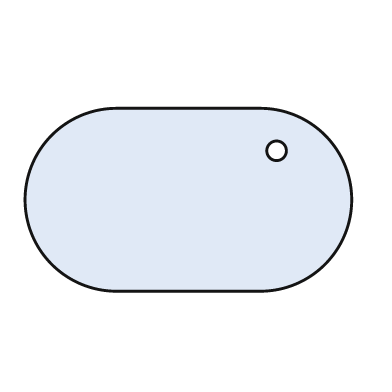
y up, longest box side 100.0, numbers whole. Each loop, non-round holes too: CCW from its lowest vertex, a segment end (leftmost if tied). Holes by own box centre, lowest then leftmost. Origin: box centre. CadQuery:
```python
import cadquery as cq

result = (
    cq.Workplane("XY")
    .moveTo(-22.0, -28.0)
    .lineTo(22.0, -28.0)
    .threePointArc((50.0, 0.0), (22.0, 28.0))
    .lineTo(-22.0, 28.0)
    .threePointArc((-50.0, 0.0), (-22.0, -28.0))
    .close()
    .moveTo(27.0, 15.0)
    .circle(3.0)
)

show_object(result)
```